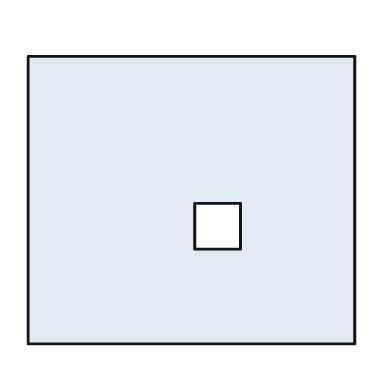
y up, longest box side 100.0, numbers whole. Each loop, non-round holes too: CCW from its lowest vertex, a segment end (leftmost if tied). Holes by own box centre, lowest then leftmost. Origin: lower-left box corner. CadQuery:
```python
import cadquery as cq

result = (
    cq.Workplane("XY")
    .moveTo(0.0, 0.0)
    .lineTo(100.0, 0.0)
    .lineTo(100.0, 88.0)
    .lineTo(0.0, 88.0)
    .close()
    .moveTo(51.0, 29.0)
    .lineTo(65.0, 29.0)
    .lineTo(65.0, 43.0)
    .lineTo(51.0, 43.0)
    .close()
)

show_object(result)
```